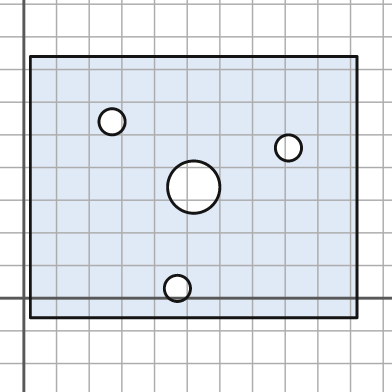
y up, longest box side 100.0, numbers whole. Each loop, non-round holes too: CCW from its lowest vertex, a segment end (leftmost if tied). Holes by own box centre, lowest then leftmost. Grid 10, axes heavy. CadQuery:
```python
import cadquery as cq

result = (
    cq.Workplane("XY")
    .moveTo(2.0, -6.0)
    .lineTo(102.0, -6.0)
    .lineTo(102.0, 74.0)
    .lineTo(2.0, 74.0)
    .close()
    .moveTo(47.0, 3.0)
    .circle(4.0)
    .moveTo(52.0, 34.0)
    .circle(8.0)
    .moveTo(81.0, 46.0)
    .circle(4.0)
    .moveTo(27.0, 54.0)
    .circle(4.0)
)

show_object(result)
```